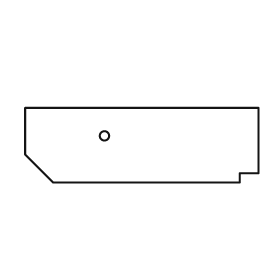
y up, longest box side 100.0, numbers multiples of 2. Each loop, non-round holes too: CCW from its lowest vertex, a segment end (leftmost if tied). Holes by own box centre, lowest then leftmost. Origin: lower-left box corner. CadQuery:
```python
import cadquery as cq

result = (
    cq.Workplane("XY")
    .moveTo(12.0, 0.0)
    .lineTo(92.0, 0.0)
    .lineTo(92.0, 4.0)
    .lineTo(100.0, 4.0)
    .lineTo(100.0, 32.0)
    .lineTo(0.0, 32.0)
    .lineTo(0.0, 12.0)
    .close()
    .moveTo(34.0, 20.0)
    .circle(2.0)
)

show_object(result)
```